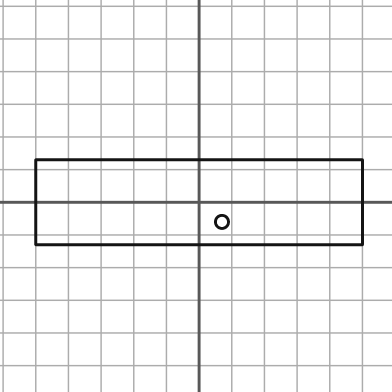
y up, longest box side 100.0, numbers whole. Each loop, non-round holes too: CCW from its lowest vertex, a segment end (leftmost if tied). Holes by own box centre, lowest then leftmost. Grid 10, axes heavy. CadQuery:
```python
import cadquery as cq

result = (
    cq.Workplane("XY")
    .moveTo(-50.0, -13.0)
    .lineTo(50.0, -13.0)
    .lineTo(50.0, 13.0)
    .lineTo(-50.0, 13.0)
    .close()
    .moveTo(7.0, -6.0)
    .circle(2.0)
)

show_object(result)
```